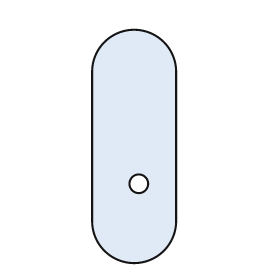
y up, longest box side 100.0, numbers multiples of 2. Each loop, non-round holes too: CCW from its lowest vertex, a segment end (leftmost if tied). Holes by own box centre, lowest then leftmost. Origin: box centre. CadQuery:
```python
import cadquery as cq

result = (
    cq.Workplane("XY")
    .moveTo(-18.0, -32.0)
    .threePointArc((0.0, -50.0), (18.0, -32.0))
    .lineTo(18.0, 32.0)
    .threePointArc((0.0, 50.0), (-18.0, 32.0))
    .close()
    .moveTo(2.0, -16.0)
    .circle(4.0)
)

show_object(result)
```